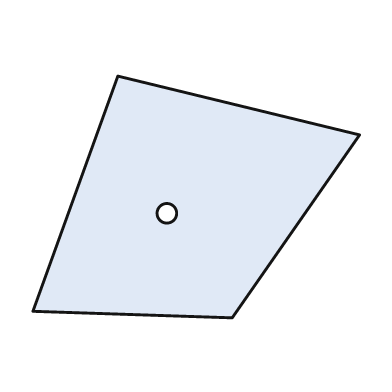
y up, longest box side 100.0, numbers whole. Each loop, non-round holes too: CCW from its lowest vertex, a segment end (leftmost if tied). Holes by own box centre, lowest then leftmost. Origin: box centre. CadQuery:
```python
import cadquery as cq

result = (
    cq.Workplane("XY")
    .moveTo(11.0, -37.0)
    .lineTo(50.0, 19.0)
    .lineTo(-24.0, 37.0)
    .lineTo(-50.0, -35.0)
    .close()
    .moveTo(-9.0, -5.0)
    .circle(3.0)
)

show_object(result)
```